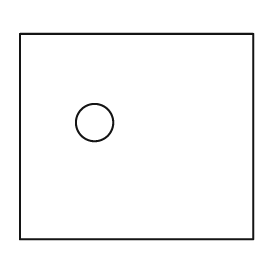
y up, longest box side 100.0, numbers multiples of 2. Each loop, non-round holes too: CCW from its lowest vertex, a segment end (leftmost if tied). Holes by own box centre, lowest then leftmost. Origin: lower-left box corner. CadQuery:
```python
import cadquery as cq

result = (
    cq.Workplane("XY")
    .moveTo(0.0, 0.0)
    .lineTo(100.0, 0.0)
    .lineTo(100.0, 88.0)
    .lineTo(0.0, 88.0)
    .close()
    .moveTo(32.0, 50.0)
    .circle(8.0)
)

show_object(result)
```